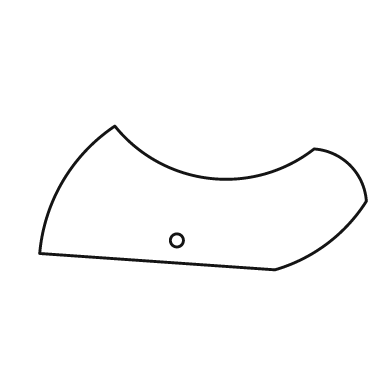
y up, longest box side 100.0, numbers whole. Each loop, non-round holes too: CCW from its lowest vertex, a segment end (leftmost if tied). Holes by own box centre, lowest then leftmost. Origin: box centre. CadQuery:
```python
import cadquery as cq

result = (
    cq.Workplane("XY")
    .moveTo(22.0, -22.0)
    .threePointArc((38.0, -14.0), (50.0, -1.0))
    .threePointArc((45.0, 10.0), (34.0, 15.0))
    .threePointArc((2.0, 6.0), (-27.0, 22.0))
    .threePointArc((-43.0, 5.0), (-50.0, -17.0))
    .close()
    .moveTo(-8.0, -13.0)
    .circle(2.0)
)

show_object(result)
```